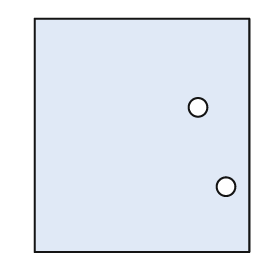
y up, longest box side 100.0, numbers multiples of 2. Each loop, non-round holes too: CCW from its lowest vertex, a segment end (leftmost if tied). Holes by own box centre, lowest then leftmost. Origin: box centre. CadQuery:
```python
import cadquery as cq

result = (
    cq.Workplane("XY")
    .moveTo(-46.0, -50.0)
    .lineTo(46.0, -50.0)
    .lineTo(46.0, 50.0)
    .lineTo(-46.0, 50.0)
    .close()
    .moveTo(36.0, -22.0)
    .circle(4.0)
    .moveTo(24.0, 12.0)
    .circle(4.0)
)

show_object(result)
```